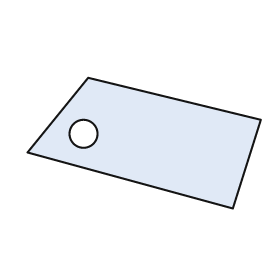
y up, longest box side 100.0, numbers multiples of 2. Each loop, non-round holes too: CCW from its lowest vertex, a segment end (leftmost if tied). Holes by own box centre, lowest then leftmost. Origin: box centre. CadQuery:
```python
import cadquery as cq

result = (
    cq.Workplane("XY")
    .moveTo(38.0, -28.0)
    .lineTo(50.0, 10.0)
    .lineTo(-24.0, 28.0)
    .lineTo(-50.0, -4.0)
    .close()
    .moveTo(-26.0, 4.0)
    .circle(6.0)
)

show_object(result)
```